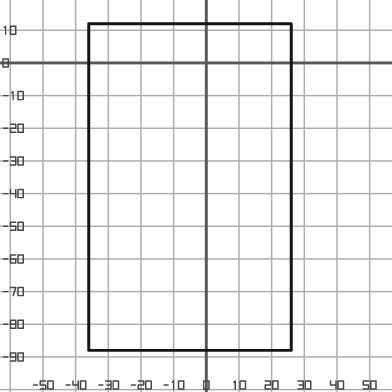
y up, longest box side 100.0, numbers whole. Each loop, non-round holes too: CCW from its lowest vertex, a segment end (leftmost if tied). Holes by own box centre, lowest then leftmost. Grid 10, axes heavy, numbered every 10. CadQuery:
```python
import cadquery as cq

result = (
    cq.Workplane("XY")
    .moveTo(-36.0, -88.0)
    .lineTo(26.0, -88.0)
    .lineTo(26.0, 12.0)
    .lineTo(-36.0, 12.0)
    .close()
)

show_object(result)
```